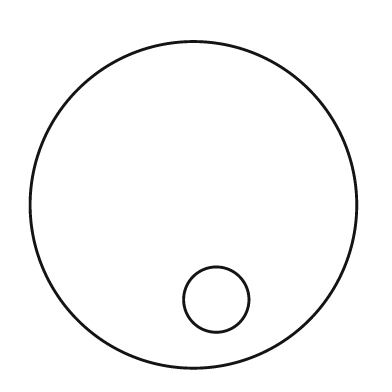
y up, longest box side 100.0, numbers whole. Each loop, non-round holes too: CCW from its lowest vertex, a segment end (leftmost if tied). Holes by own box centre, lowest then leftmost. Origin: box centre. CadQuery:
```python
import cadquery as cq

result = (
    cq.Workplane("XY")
    .moveTo(0.0, 0.0)
    .circle(50.0)
    .moveTo(7.0, -29.0)
    .circle(10.0)
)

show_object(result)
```